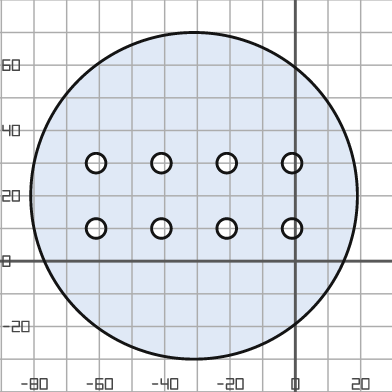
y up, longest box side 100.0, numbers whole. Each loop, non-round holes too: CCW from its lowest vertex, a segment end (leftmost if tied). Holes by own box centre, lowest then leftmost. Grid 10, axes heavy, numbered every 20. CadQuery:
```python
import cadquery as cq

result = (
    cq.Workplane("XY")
    .moveTo(-31.0, 20.0)
    .circle(50.0)
    .moveTo(-61.0, 10.0)
    .circle(3.0)
    .moveTo(-41.0, 10.0)
    .circle(3.0)
    .moveTo(-21.0, 10.0)
    .circle(3.0)
    .moveTo(-1.0, 10.0)
    .circle(3.0)
    .moveTo(-61.0, 30.0)
    .circle(3.0)
    .moveTo(-41.0, 30.0)
    .circle(3.0)
    .moveTo(-21.0, 30.0)
    .circle(3.0)
    .moveTo(-1.0, 30.0)
    .circle(3.0)
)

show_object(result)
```